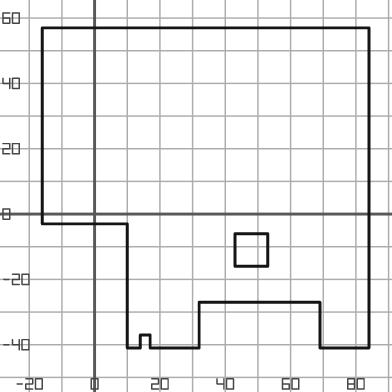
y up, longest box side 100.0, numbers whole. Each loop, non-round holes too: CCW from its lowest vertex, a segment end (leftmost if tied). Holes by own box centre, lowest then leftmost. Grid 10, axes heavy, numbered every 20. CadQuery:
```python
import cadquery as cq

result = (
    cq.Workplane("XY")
    .moveTo(10.0, -41.0)
    .lineTo(14.0, -41.0)
    .lineTo(14.0, -37.0)
    .lineTo(17.0, -37.0)
    .lineTo(17.0, -41.0)
    .lineTo(32.0, -41.0)
    .lineTo(32.0, -27.0)
    .lineTo(69.0, -27.0)
    .lineTo(69.0, -41.0)
    .lineTo(84.0, -41.0)
    .lineTo(84.0, 57.0)
    .lineTo(-16.0, 57.0)
    .lineTo(-16.0, -3.0)
    .lineTo(10.0, -3.0)
    .close()
    .moveTo(43.0, -16.0)
    .lineTo(53.0, -16.0)
    .lineTo(53.0, -6.0)
    .lineTo(43.0, -6.0)
    .close()
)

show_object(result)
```